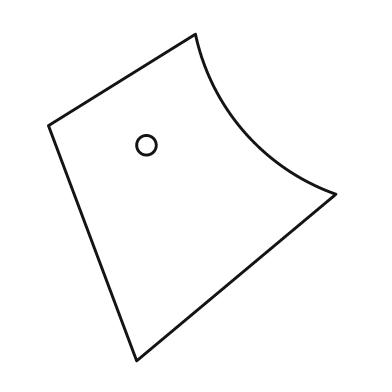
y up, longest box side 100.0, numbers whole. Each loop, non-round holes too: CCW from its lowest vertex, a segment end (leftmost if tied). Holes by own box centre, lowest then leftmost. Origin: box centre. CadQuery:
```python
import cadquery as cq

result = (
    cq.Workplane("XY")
    .moveTo(-17.0, -50.0)
    .lineTo(44.0, 1.0)
    .threePointArc((16.0, 20.0), (1.0, 50.0))
    .lineTo(-44.0, 22.0)
    .close()
    .moveTo(-14.0, 16.0)
    .circle(3.0)
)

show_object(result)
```